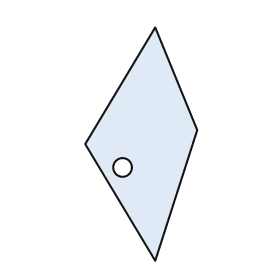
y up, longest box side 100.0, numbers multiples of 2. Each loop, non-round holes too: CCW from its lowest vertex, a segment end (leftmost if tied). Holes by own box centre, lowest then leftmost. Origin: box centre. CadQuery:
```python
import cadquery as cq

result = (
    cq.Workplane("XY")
    .moveTo(6.0, -50.0)
    .lineTo(24.0, 6.0)
    .lineTo(6.0, 50.0)
    .lineTo(-24.0, 0.0)
    .close()
    .moveTo(-8.0, -10.0)
    .circle(4.0)
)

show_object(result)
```